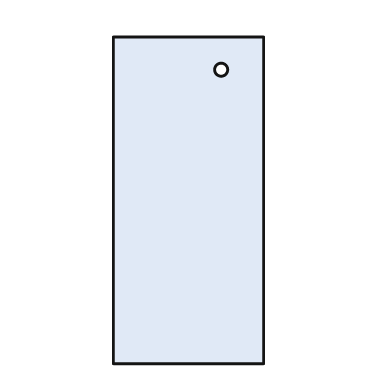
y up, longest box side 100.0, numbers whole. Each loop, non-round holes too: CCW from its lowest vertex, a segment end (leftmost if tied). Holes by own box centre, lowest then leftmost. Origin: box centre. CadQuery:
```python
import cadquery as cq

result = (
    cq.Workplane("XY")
    .moveTo(-23.0, -50.0)
    .lineTo(23.0, -50.0)
    .lineTo(23.0, 50.0)
    .lineTo(-23.0, 50.0)
    .close()
    .moveTo(10.0, 40.0)
    .circle(2.0)
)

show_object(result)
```